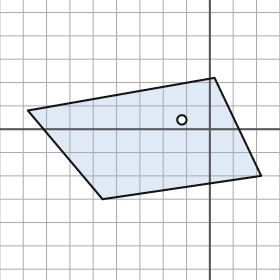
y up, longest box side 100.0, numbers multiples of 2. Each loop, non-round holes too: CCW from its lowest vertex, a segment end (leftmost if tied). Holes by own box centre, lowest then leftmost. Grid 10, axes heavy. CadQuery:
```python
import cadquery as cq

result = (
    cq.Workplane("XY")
    .moveTo(-46.0, -30.0)
    .lineTo(22.0, -20.0)
    .lineTo(2.0, 22.0)
    .lineTo(-78.0, 8.0)
    .close()
    .moveTo(-12.0, 4.0)
    .circle(2.0)
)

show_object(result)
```